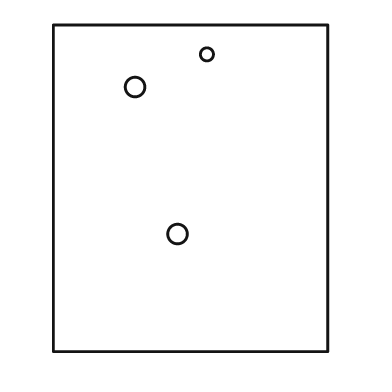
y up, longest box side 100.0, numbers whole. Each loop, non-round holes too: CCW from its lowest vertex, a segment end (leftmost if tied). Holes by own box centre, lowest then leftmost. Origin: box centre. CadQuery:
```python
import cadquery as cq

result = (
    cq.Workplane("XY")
    .moveTo(-42.0, -50.0)
    .lineTo(42.0, -50.0)
    .lineTo(42.0, 50.0)
    .lineTo(-42.0, 50.0)
    .close()
    .moveTo(-4.0, -14.0)
    .circle(3.0)
    .moveTo(-17.0, 31.0)
    .circle(3.0)
    .moveTo(5.0, 41.0)
    .circle(2.0)
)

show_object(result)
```